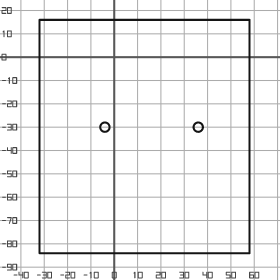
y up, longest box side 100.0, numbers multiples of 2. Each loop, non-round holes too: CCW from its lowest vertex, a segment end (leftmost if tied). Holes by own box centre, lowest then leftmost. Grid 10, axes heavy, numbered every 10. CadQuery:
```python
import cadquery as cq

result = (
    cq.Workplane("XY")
    .moveTo(-32.0, -84.0)
    .lineTo(58.0, -84.0)
    .lineTo(58.0, 16.0)
    .lineTo(-32.0, 16.0)
    .close()
    .moveTo(-4.0, -30.0)
    .circle(2.0)
    .moveTo(36.0, -30.0)
    .circle(2.0)
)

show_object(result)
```